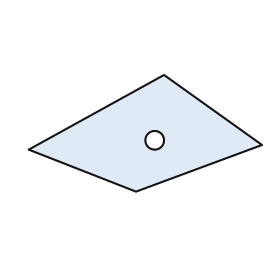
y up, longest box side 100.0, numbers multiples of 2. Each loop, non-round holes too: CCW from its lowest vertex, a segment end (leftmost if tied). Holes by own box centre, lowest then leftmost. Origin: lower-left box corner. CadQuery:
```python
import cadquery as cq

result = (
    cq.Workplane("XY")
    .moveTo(46.0, 0.0)
    .lineTo(100.0, 20.0)
    .lineTo(58.0, 50.0)
    .lineTo(0.0, 18.0)
    .close()
    .moveTo(54.0, 22.0)
    .circle(4.0)
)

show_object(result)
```